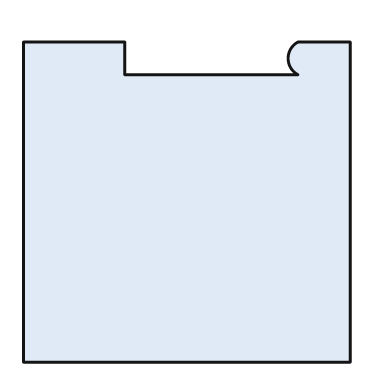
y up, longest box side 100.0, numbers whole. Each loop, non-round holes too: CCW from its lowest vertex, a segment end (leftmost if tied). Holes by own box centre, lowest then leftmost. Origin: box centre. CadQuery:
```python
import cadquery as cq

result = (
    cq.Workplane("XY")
    .moveTo(-50.0, -49.0)
    .lineTo(50.0, -49.0)
    .lineTo(50.0, 49.0)
    .lineTo(34.0, 49.0)
    .threePointArc((31.0, 44.0), (34.0, 39.0))
    .lineTo(-19.0, 39.0)
    .lineTo(-19.0, 49.0)
    .lineTo(-50.0, 49.0)
    .close()
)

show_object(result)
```